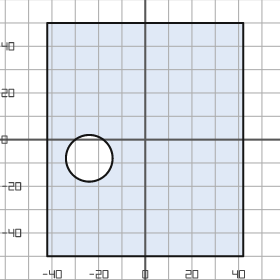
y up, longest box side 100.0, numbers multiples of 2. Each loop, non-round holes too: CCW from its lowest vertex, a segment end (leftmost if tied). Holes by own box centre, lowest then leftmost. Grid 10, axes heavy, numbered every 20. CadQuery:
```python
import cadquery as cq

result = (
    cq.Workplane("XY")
    .moveTo(-42.0, -50.0)
    .lineTo(42.0, -50.0)
    .lineTo(42.0, 50.0)
    .lineTo(-42.0, 50.0)
    .close()
    .moveTo(-24.0, -8.0)
    .circle(10.0)
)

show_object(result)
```